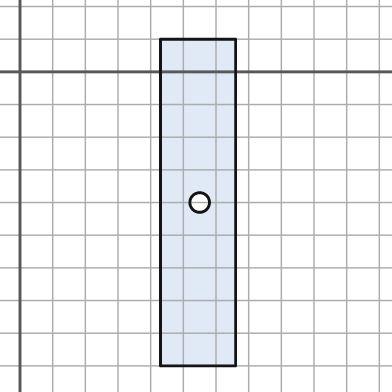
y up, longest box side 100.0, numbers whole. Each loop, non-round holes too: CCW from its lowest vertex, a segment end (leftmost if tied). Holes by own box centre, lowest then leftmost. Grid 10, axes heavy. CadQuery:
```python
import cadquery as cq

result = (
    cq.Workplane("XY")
    .moveTo(43.0, -90.0)
    .lineTo(66.0, -90.0)
    .lineTo(66.0, 10.0)
    .lineTo(43.0, 10.0)
    .close()
    .moveTo(55.0, -40.0)
    .circle(3.0)
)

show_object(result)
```